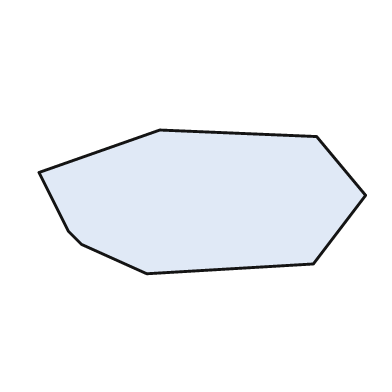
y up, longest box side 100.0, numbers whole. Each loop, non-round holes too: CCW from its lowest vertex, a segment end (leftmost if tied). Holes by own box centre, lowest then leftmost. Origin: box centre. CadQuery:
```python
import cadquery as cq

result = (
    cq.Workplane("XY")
    .moveTo(-17.0, -22.0)
    .lineTo(34.0, -19.0)
    .lineTo(50.0, 2.0)
    .lineTo(35.0, 20.0)
    .lineTo(-13.0, 22.0)
    .lineTo(-50.0, 9.0)
    .lineTo(-41.0, -9.0)
    .lineTo(-37.0, -13.0)
    .close()
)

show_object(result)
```